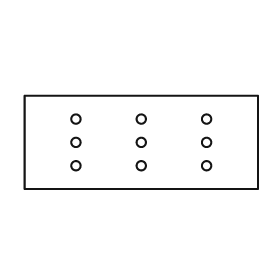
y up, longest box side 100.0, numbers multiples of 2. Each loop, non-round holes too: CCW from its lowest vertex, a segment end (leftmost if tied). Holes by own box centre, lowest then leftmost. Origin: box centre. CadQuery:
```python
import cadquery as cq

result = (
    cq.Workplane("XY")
    .moveTo(-50.0, -20.0)
    .lineTo(50.0, -20.0)
    .lineTo(50.0, 20.0)
    .lineTo(-50.0, 20.0)
    .close()
    .moveTo(-28.0, -10.0)
    .circle(2.0)
    .moveTo(0.0, -10.0)
    .circle(2.0)
    .moveTo(28.0, -10.0)
    .circle(2.0)
    .moveTo(-28.0, 0.0)
    .circle(2.0)
    .moveTo(0.0, 0.0)
    .circle(2.0)
    .moveTo(28.0, 0.0)
    .circle(2.0)
    .moveTo(-28.0, 10.0)
    .circle(2.0)
    .moveTo(0.0, 10.0)
    .circle(2.0)
    .moveTo(28.0, 10.0)
    .circle(2.0)
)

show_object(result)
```